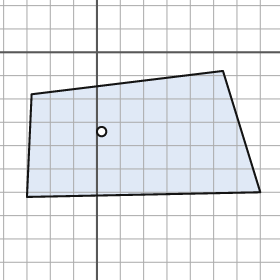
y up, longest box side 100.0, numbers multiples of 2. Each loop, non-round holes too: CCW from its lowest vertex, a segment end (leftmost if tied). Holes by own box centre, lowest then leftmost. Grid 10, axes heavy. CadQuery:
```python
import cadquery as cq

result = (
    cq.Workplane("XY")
    .moveTo(-30.0, -62.0)
    .lineTo(70.0, -60.0)
    .lineTo(54.0, -8.0)
    .lineTo(-28.0, -18.0)
    .close()
    .moveTo(2.0, -34.0)
    .circle(2.0)
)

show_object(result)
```